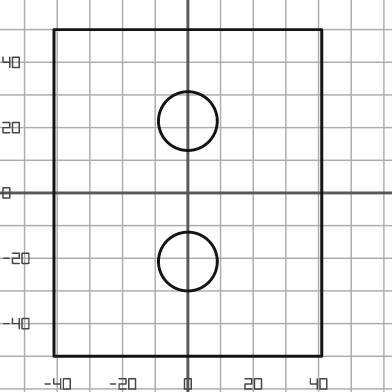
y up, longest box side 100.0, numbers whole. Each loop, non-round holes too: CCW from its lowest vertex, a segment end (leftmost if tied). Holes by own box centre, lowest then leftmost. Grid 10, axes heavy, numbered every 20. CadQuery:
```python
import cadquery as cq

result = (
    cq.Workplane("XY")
    .moveTo(-41.0, -50.0)
    .lineTo(41.0, -50.0)
    .lineTo(41.0, 50.0)
    .lineTo(-41.0, 50.0)
    .close()
    .moveTo(0.0, -21.0)
    .circle(9.0)
    .moveTo(0.0, 22.0)
    .circle(9.0)
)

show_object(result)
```